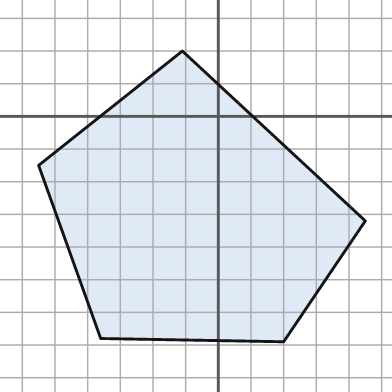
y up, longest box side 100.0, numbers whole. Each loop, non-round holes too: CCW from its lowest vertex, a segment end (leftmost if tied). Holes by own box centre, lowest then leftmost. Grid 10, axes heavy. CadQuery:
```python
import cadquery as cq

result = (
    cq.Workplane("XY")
    .moveTo(20.0, -69.0)
    .lineTo(45.0, -32.0)
    .lineTo(-11.0, 20.0)
    .lineTo(-55.0, -15.0)
    .lineTo(-36.0, -68.0)
    .close()
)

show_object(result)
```